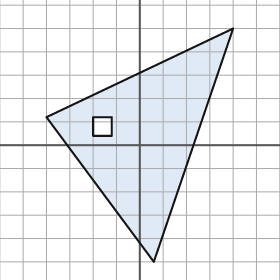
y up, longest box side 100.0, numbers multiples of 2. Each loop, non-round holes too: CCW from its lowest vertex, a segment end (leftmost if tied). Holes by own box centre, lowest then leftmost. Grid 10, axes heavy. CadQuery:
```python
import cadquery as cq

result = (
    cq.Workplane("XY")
    .moveTo(6.0, -50.0)
    .lineTo(40.0, 50.0)
    .lineTo(-40.0, 12.0)
    .close()
    .moveTo(-20.0, 4.0)
    .lineTo(-12.0, 4.0)
    .lineTo(-12.0, 12.0)
    .lineTo(-20.0, 12.0)
    .close()
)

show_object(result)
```